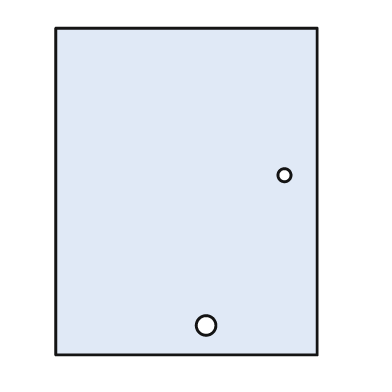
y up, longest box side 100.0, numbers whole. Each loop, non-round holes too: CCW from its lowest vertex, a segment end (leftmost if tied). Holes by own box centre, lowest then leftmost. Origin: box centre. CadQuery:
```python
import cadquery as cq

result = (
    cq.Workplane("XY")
    .moveTo(-40.0, -50.0)
    .lineTo(40.0, -50.0)
    .lineTo(40.0, 50.0)
    .lineTo(-40.0, 50.0)
    .close()
    .moveTo(6.0, -41.0)
    .circle(3.0)
    .moveTo(30.0, 5.0)
    .circle(2.0)
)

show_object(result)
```